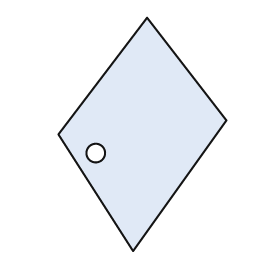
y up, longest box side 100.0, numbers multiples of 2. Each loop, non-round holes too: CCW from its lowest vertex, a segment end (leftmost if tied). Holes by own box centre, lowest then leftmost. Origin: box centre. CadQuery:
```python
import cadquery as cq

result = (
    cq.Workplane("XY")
    .moveTo(-4.0, -50.0)
    .lineTo(36.0, 6.0)
    .lineTo(2.0, 50.0)
    .lineTo(-36.0, 0.0)
    .close()
    .moveTo(-20.0, -8.0)
    .circle(4.0)
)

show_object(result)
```